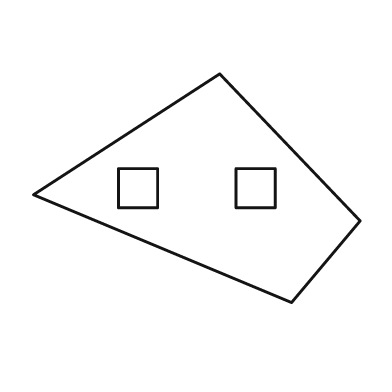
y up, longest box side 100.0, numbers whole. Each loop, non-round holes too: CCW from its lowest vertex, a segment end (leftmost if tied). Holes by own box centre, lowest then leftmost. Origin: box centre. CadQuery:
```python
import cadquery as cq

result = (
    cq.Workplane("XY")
    .moveTo(29.0, -35.0)
    .lineTo(50.0, -10.0)
    .lineTo(7.0, 35.0)
    .lineTo(-50.0, -2.0)
    .close()
    .moveTo(-24.0, -6.0)
    .lineTo(-12.0, -6.0)
    .lineTo(-12.0, 6.0)
    .lineTo(-24.0, 6.0)
    .close()
    .moveTo(12.0, -6.0)
    .lineTo(24.0, -6.0)
    .lineTo(24.0, 6.0)
    .lineTo(12.0, 6.0)
    .close()
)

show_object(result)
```